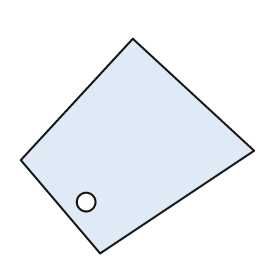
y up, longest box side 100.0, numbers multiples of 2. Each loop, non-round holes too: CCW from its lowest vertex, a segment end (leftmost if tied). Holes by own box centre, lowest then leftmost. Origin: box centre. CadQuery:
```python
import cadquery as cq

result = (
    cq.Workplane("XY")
    .moveTo(-16.0, -46.0)
    .lineTo(50.0, -2.0)
    .lineTo(-2.0, 46.0)
    .lineTo(-50.0, -6.0)
    .close()
    .moveTo(-22.0, -24.0)
    .circle(4.0)
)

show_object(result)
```